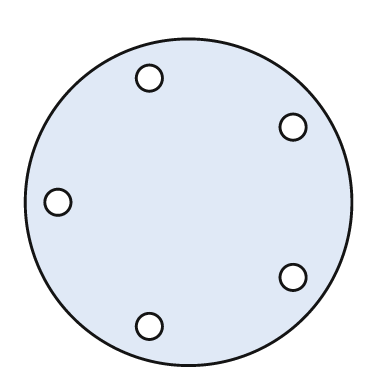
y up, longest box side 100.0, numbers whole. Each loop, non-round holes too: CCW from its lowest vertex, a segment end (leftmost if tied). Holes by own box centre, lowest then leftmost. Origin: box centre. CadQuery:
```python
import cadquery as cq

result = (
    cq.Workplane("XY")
    .moveTo(0.0, 0.0)
    .circle(50.0)
    .moveTo(-12.0, -38.0)
    .circle(4.0)
    .moveTo(32.0, -23.0)
    .circle(4.0)
    .moveTo(-40.0, 0.0)
    .circle(4.0)
    .moveTo(32.0, 23.0)
    .circle(4.0)
    .moveTo(-12.0, 38.0)
    .circle(4.0)
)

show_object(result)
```